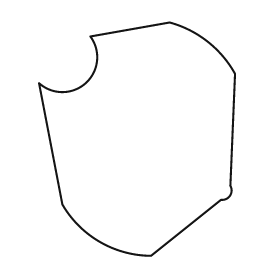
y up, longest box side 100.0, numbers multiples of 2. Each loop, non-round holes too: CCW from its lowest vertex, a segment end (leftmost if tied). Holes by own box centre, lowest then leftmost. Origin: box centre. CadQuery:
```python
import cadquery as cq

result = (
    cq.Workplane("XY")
    .moveTo(6.0, -50.0)
    .lineTo(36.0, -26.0)
    .threePointArc((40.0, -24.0), (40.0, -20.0))
    .lineTo(42.0, 28.0)
    .threePointArc((30.0, 42.0), (14.0, 50.0))
    .lineTo(-20.0, 44.0)
    .threePointArc((-22.0, 24.0), (-42.0, 24.0))
    .lineTo(-32.0, -28.0)
    .threePointArc((-16.0, -44.0), (6.0, -50.0))
    .close()
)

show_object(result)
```